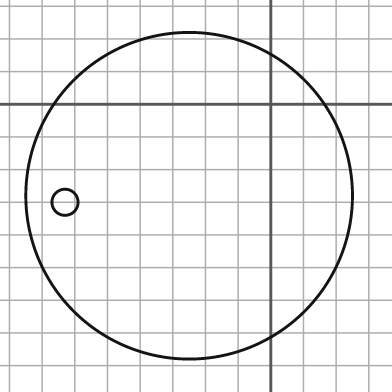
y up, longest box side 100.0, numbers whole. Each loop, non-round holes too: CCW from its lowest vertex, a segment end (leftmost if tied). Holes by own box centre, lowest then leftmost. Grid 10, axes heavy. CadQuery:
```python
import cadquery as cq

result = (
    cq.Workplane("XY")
    .moveTo(-25.0, -28.0)
    .circle(50.0)
    .moveTo(-63.0, -30.0)
    .circle(4.0)
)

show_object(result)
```